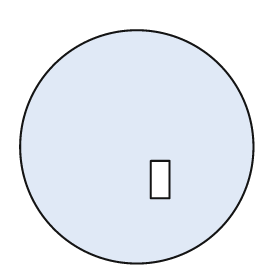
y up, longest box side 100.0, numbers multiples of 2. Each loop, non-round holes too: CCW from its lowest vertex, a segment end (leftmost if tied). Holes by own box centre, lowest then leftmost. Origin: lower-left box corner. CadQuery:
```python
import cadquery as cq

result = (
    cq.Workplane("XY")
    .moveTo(50.0, 50.0)
    .circle(50.0)
    .moveTo(56.0, 28.0)
    .lineTo(64.0, 28.0)
    .lineTo(64.0, 44.0)
    .lineTo(56.0, 44.0)
    .close()
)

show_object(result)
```